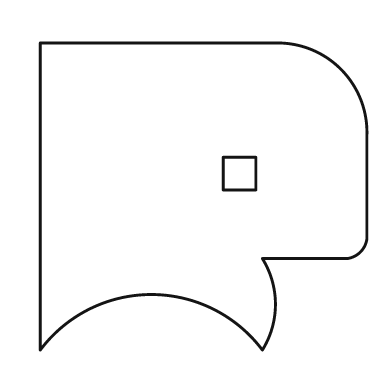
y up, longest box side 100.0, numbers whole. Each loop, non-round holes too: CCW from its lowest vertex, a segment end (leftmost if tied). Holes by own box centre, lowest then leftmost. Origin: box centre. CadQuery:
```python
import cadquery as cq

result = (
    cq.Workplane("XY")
    .moveTo(-50.0, -47.0)
    .threePointArc((-16.0, -30.0), (18.0, -47.0))
    .threePointArc((22.0, -33.0), (18.0, -19.0))
    .lineTo(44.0, -19.0)
    .threePointArc((48.0, -17.0), (50.0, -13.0))
    .lineTo(50.0, 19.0)
    .threePointArc((42.0, 39.0), (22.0, 47.0))
    .lineTo(-50.0, 47.0)
    .close()
    .moveTo(6.0, 2.0)
    .lineTo(16.0, 2.0)
    .lineTo(16.0, 12.0)
    .lineTo(6.0, 12.0)
    .close()
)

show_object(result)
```